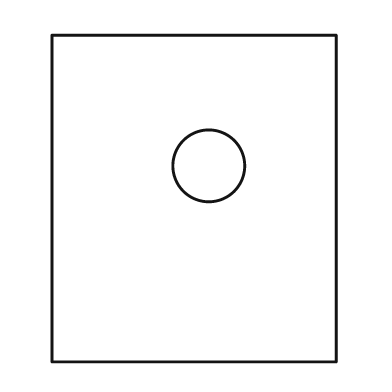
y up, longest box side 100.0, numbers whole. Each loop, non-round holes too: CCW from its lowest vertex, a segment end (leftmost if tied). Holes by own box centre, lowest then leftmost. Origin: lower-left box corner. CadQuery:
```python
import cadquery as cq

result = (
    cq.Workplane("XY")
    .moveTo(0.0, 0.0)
    .lineTo(87.0, 0.0)
    .lineTo(87.0, 100.0)
    .lineTo(0.0, 100.0)
    .close()
    .moveTo(48.0, 60.0)
    .circle(11.0)
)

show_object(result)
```